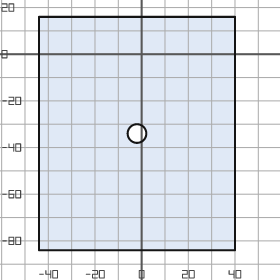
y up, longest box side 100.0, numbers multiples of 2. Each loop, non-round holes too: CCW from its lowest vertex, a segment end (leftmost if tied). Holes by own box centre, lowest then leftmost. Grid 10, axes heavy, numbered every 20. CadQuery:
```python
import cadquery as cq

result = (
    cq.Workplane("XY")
    .moveTo(-44.0, -84.0)
    .lineTo(40.0, -84.0)
    .lineTo(40.0, 16.0)
    .lineTo(-44.0, 16.0)
    .close()
    .moveTo(-2.0, -34.0)
    .circle(4.0)
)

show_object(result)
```